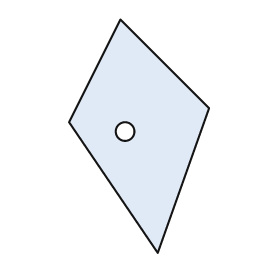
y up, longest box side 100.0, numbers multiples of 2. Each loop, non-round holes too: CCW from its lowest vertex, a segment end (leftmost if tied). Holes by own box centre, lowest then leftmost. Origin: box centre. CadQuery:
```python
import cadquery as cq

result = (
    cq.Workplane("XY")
    .moveTo(8.0, -50.0)
    .lineTo(30.0, 12.0)
    .lineTo(-8.0, 50.0)
    .lineTo(-30.0, 6.0)
    .close()
    .moveTo(-6.0, 2.0)
    .circle(4.0)
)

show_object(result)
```